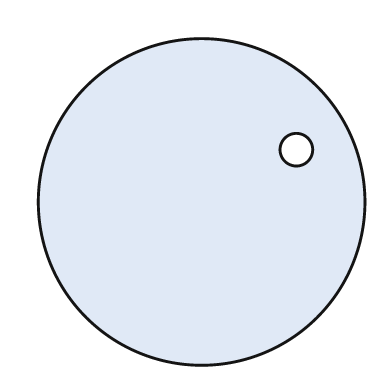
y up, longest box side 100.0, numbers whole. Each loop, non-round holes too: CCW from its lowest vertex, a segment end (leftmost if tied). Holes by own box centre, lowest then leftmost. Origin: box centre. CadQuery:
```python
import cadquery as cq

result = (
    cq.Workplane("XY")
    .moveTo(0.0, 0.0)
    .circle(50.0)
    .moveTo(29.0, 16.0)
    .circle(5.0)
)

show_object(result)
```